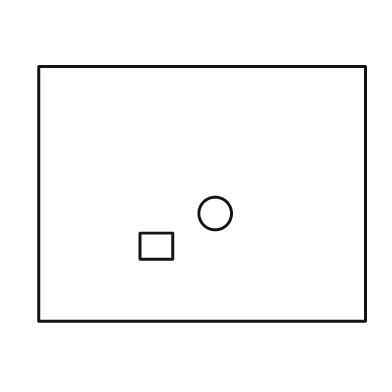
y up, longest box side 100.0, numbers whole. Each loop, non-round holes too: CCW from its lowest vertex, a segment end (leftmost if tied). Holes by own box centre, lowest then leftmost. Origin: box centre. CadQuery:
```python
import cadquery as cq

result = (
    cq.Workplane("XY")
    .moveTo(-50.0, -39.0)
    .lineTo(50.0, -39.0)
    .lineTo(50.0, 39.0)
    .lineTo(-50.0, 39.0)
    .close()
    .moveTo(-19.0, -20.0)
    .lineTo(-9.0, -20.0)
    .lineTo(-9.0, -12.0)
    .lineTo(-19.0, -12.0)
    .close()
    .moveTo(4.0, -6.0)
    .circle(5.0)
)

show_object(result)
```